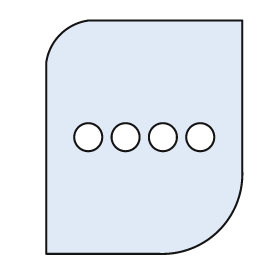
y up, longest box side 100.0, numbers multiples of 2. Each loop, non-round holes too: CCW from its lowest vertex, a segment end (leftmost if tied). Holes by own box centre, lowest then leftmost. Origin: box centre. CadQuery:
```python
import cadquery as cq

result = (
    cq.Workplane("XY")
    .moveTo(-42.0, -50.0)
    .lineTo(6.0, -50.0)
    .threePointArc((32.0, -40.0), (42.0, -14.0))
    .lineTo(42.0, 50.0)
    .lineTo(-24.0, 50.0)
    .threePointArc((-36.0, 44.0), (-42.0, 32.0))
    .close()
    .moveTo(-24.0, 0.0)
    .circle(6.0)
    .moveTo(-8.0, 0.0)
    .circle(6.0)
    .moveTo(8.0, 0.0)
    .circle(6.0)
    .moveTo(24.0, 0.0)
    .circle(6.0)
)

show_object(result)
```